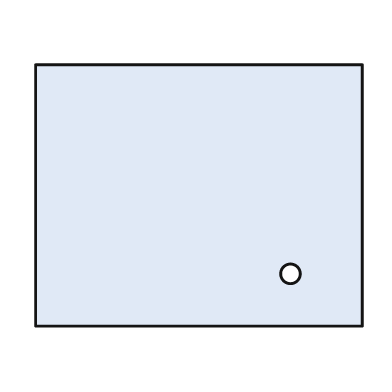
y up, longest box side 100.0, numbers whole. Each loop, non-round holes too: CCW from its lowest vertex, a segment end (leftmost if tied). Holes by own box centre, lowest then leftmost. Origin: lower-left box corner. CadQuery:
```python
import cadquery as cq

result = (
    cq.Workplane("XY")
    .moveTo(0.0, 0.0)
    .lineTo(100.0, 0.0)
    .lineTo(100.0, 80.0)
    .lineTo(0.0, 80.0)
    .close()
    .moveTo(78.0, 16.0)
    .circle(3.0)
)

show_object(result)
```